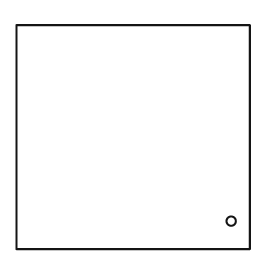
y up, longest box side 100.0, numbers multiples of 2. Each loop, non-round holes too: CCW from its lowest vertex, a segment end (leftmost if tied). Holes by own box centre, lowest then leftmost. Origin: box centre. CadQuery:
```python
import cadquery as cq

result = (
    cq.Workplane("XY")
    .moveTo(-50.0, -48.0)
    .lineTo(50.0, -48.0)
    .lineTo(50.0, 48.0)
    .lineTo(-50.0, 48.0)
    .close()
    .moveTo(42.0, -36.0)
    .circle(2.0)
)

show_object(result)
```